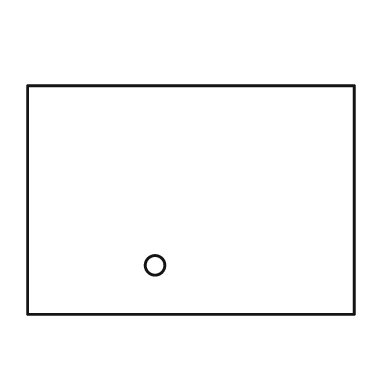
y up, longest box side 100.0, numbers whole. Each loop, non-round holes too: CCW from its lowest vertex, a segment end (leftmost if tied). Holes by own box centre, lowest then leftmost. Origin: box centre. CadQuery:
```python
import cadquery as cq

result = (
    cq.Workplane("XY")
    .moveTo(-50.0, -35.0)
    .lineTo(50.0, -35.0)
    .lineTo(50.0, 35.0)
    .lineTo(-50.0, 35.0)
    .close()
    .moveTo(-11.0, -20.0)
    .circle(3.0)
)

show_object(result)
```